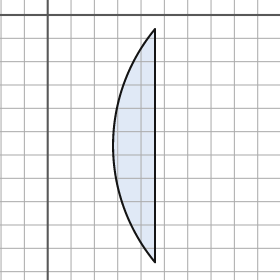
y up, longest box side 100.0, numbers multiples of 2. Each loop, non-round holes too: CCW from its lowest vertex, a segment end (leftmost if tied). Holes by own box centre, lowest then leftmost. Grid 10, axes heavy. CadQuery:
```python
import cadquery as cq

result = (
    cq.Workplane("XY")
    .moveTo(46.0, -106.0)
    .lineTo(46.0, -6.0)
    .threePointArc((28.0, -56.0), (46.0, -106.0))
    .close()
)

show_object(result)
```